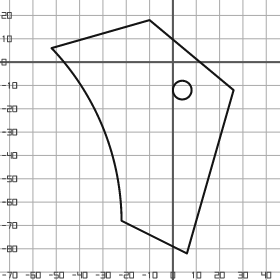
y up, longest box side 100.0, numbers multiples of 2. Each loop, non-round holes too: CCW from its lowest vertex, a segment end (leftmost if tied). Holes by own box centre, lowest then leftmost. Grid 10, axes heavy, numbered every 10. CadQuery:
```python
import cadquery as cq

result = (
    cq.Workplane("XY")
    .moveTo(6.0, -82.0)
    .lineTo(26.0, -12.0)
    .lineTo(-10.0, 18.0)
    .lineTo(-52.0, 6.0)
    .threePointArc((-30.0, -28.0), (-22.0, -68.0))
    .close()
    .moveTo(4.0, -12.0)
    .circle(4.0)
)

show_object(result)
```